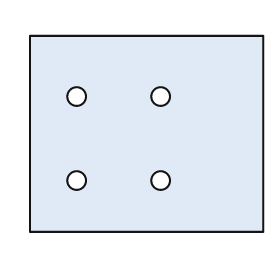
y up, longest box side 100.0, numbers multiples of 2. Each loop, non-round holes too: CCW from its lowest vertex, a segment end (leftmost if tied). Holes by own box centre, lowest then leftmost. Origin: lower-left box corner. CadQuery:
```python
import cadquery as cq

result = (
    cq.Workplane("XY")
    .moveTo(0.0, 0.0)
    .lineTo(100.0, 0.0)
    .lineTo(100.0, 84.0)
    .lineTo(0.0, 84.0)
    .close()
    .moveTo(20.0, 22.0)
    .circle(4.0)
    .moveTo(56.0, 22.0)
    .circle(4.0)
    .moveTo(20.0, 58.0)
    .circle(4.0)
    .moveTo(56.0, 58.0)
    .circle(4.0)
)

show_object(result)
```